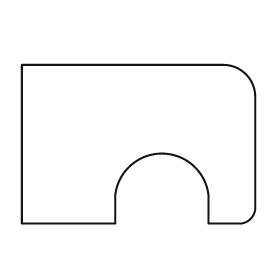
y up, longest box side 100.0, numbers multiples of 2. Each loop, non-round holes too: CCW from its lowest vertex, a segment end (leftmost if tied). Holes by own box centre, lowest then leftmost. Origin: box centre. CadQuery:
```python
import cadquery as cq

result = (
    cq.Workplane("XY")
    .moveTo(-50.0, -34.0)
    .lineTo(-10.0, -34.0)
    .lineTo(-10.0, -22.0)
    .threePointArc((10.0, -4.0), (30.0, -22.0))
    .lineTo(30.0, -34.0)
    .lineTo(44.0, -34.0)
    .threePointArc((48.0, -32.0), (50.0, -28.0))
    .lineTo(50.0, 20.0)
    .threePointArc((46.0, 30.0), (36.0, 34.0))
    .lineTo(-50.0, 34.0)
    .close()
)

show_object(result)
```